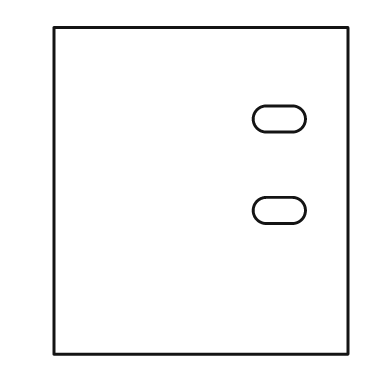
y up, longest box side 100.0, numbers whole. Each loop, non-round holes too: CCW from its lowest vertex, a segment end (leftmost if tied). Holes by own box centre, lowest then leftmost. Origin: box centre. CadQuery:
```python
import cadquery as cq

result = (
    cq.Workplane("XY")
    .moveTo(-45.0, -50.0)
    .lineTo(45.0, -50.0)
    .lineTo(45.0, 50.0)
    .lineTo(-45.0, 50.0)
    .close()
    .moveTo(20.0, -10.0)
    .lineTo(28.0, -10.0)
    .threePointArc((32.0, -6.0), (28.0, -2.0))
    .lineTo(20.0, -2.0)
    .threePointArc((16.0, -6.0), (20.0, -10.0))
    .close()
    .moveTo(20.0, 18.0)
    .lineTo(28.0, 18.0)
    .threePointArc((32.0, 22.0), (28.0, 26.0))
    .lineTo(20.0, 26.0)
    .threePointArc((16.0, 22.0), (20.0, 18.0))
    .close()
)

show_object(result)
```